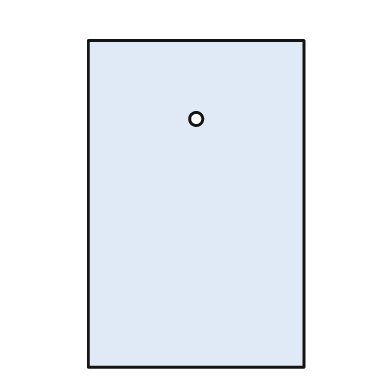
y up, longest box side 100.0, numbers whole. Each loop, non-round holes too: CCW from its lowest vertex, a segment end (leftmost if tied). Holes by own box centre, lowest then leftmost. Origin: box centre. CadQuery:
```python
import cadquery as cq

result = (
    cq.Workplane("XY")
    .moveTo(-33.0, -50.0)
    .lineTo(33.0, -50.0)
    .lineTo(33.0, 50.0)
    .lineTo(-33.0, 50.0)
    .close()
    .moveTo(0.0, 26.0)
    .circle(2.0)
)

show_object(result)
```